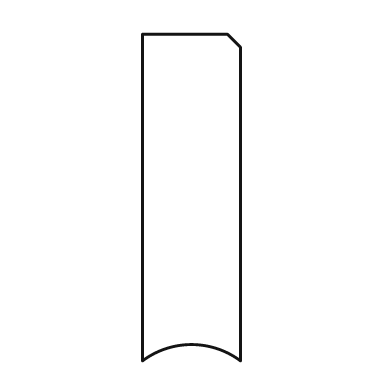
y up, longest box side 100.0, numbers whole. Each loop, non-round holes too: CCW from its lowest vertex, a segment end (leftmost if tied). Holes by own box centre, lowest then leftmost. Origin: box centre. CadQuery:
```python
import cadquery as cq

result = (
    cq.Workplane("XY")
    .moveTo(-15.0, -50.0)
    .threePointArc((0.0, -45.0), (15.0, -50.0))
    .lineTo(15.0, 46.0)
    .lineTo(11.0, 50.0)
    .lineTo(-15.0, 50.0)
    .close()
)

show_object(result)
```